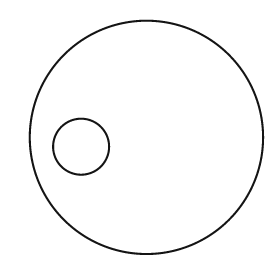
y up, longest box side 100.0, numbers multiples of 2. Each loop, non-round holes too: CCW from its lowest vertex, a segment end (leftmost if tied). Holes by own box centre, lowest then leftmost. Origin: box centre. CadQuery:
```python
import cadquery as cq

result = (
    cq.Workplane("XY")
    .moveTo(0.0, 0.0)
    .circle(50.0)
    .moveTo(-28.0, -4.0)
    .circle(12.0)
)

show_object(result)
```